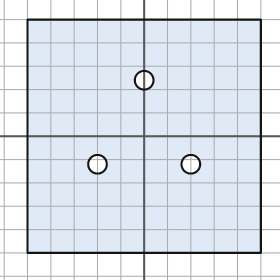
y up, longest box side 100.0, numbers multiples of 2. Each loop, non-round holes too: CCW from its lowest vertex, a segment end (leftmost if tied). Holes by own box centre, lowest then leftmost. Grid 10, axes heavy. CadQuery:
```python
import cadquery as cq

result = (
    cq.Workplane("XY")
    .moveTo(-50.0, -50.0)
    .lineTo(50.0, -50.0)
    .lineTo(50.0, 50.0)
    .lineTo(-50.0, 50.0)
    .close()
    .moveTo(-20.0, -12.0)
    .circle(4.0)
    .moveTo(20.0, -12.0)
    .circle(4.0)
    .moveTo(0.0, 24.0)
    .circle(4.0)
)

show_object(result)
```